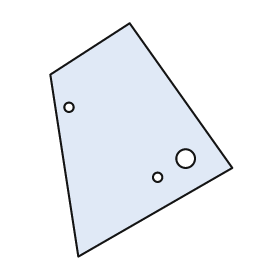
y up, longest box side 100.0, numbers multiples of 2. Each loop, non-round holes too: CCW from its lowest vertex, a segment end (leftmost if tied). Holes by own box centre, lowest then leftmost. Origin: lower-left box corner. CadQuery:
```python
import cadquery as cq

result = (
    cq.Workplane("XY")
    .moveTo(12.0, 0.0)
    .lineTo(78.0, 38.0)
    .lineTo(34.0, 100.0)
    .lineTo(0.0, 78.0)
    .close()
    .moveTo(46.0, 34.0)
    .circle(2.0)
    .moveTo(58.0, 42.0)
    .circle(4.0)
    .moveTo(8.0, 64.0)
    .circle(2.0)
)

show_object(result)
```